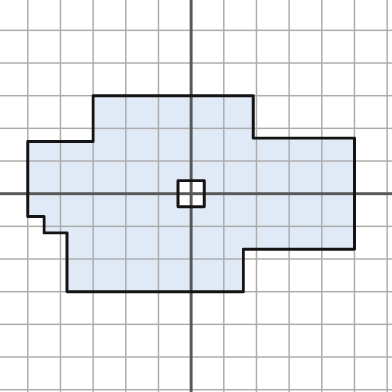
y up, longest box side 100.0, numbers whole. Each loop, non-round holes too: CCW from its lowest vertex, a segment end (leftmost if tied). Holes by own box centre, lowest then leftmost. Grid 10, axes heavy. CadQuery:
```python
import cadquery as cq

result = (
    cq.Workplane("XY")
    .moveTo(-38.0, -30.0)
    .lineTo(16.0, -30.0)
    .lineTo(16.0, -17.0)
    .lineTo(50.0, -17.0)
    .lineTo(50.0, 17.0)
    .lineTo(19.0, 17.0)
    .lineTo(19.0, 30.0)
    .lineTo(-30.0, 30.0)
    .lineTo(-30.0, 16.0)
    .lineTo(-50.0, 16.0)
    .lineTo(-50.0, -7.0)
    .lineTo(-45.0, -7.0)
    .lineTo(-45.0, -12.0)
    .lineTo(-38.0, -12.0)
    .close()
    .moveTo(-4.0, -4.0)
    .lineTo(4.0, -4.0)
    .lineTo(4.0, 4.0)
    .lineTo(-4.0, 4.0)
    .close()
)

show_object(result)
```